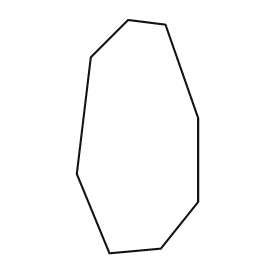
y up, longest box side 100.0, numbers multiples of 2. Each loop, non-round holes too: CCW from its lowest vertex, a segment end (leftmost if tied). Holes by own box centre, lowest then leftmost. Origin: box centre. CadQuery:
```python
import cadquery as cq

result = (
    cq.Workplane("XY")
    .moveTo(-12.0, -50.0)
    .lineTo(10.0, -48.0)
    .lineTo(26.0, -28.0)
    .lineTo(26.0, 8.0)
    .lineTo(12.0, 48.0)
    .lineTo(-4.0, 50.0)
    .lineTo(-20.0, 34.0)
    .lineTo(-26.0, -16.0)
    .close()
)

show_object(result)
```